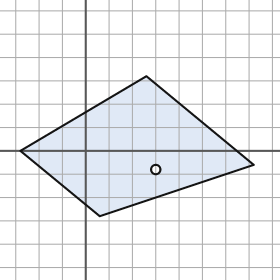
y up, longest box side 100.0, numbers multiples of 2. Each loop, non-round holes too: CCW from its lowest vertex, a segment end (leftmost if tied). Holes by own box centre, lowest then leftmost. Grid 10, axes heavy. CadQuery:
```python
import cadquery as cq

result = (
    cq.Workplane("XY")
    .moveTo(6.0, -28.0)
    .lineTo(72.0, -6.0)
    .lineTo(26.0, 32.0)
    .lineTo(-28.0, 0.0)
    .close()
    .moveTo(30.0, -8.0)
    .circle(2.0)
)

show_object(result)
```